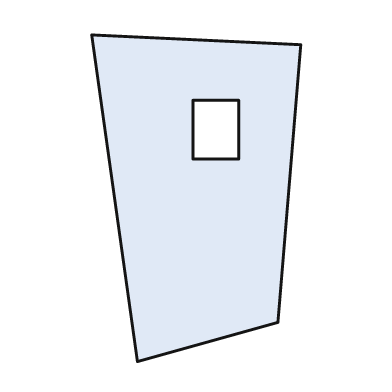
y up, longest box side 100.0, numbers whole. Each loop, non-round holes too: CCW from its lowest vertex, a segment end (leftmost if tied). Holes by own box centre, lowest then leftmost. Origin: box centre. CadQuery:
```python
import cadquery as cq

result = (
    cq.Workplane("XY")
    .moveTo(-18.0, -50.0)
    .lineTo(25.0, -38.0)
    .lineTo(32.0, 47.0)
    .lineTo(-32.0, 50.0)
    .close()
    .moveTo(-1.0, 12.0)
    .lineTo(13.0, 12.0)
    .lineTo(13.0, 30.0)
    .lineTo(-1.0, 30.0)
    .close()
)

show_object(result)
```